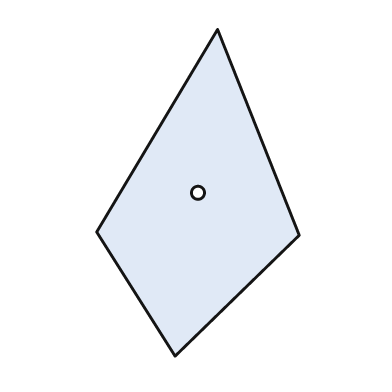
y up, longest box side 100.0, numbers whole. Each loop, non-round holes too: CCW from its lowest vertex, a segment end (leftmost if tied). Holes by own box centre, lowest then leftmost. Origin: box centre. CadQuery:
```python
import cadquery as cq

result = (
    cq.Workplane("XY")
    .moveTo(-7.0, -50.0)
    .lineTo(31.0, -13.0)
    .lineTo(6.0, 50.0)
    .lineTo(-31.0, -12.0)
    .close()
    .moveTo(0.0, 0.0)
    .circle(2.0)
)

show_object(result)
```